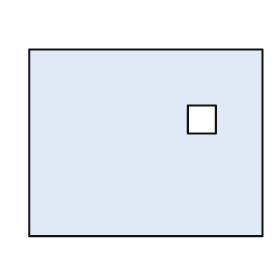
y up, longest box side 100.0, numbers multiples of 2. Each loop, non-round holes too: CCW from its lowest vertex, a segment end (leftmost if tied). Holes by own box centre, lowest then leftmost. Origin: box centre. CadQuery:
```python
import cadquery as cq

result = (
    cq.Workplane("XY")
    .moveTo(-50.0, -40.0)
    .lineTo(50.0, -40.0)
    .lineTo(50.0, 40.0)
    .lineTo(-50.0, 40.0)
    .close()
    .moveTo(18.0, 4.0)
    .lineTo(30.0, 4.0)
    .lineTo(30.0, 16.0)
    .lineTo(18.0, 16.0)
    .close()
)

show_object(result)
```